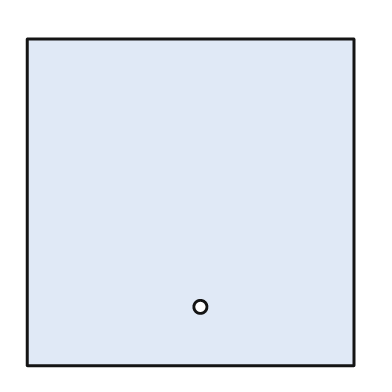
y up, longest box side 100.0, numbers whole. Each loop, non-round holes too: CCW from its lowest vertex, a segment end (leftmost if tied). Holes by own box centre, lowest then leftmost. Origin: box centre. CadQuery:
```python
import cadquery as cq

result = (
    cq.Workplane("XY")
    .moveTo(-50.0, -50.0)
    .lineTo(50.0, -50.0)
    .lineTo(50.0, 50.0)
    .lineTo(-50.0, 50.0)
    .close()
    .moveTo(3.0, -32.0)
    .circle(2.0)
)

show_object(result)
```